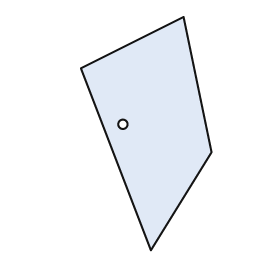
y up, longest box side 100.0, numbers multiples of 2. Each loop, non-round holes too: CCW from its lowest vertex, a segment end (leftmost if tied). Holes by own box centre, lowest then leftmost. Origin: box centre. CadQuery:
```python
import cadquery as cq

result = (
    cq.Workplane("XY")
    .moveTo(2.0, -50.0)
    .lineTo(28.0, -8.0)
    .lineTo(16.0, 50.0)
    .lineTo(-28.0, 28.0)
    .close()
    .moveTo(-10.0, 4.0)
    .circle(2.0)
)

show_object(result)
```